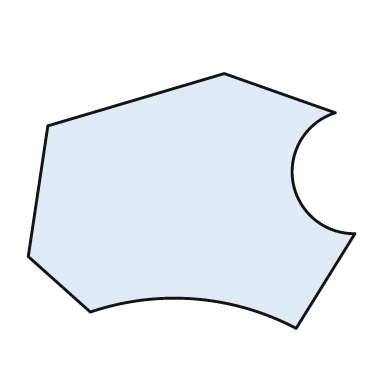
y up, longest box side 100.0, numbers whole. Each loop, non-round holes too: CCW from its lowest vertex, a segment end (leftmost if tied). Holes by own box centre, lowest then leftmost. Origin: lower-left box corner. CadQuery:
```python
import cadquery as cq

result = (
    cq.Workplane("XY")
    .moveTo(82.0, 0.0)
    .lineTo(100.0, 29.0)
    .threePointArc((81.0, 45.0), (94.0, 66.0))
    .lineTo(60.0, 78.0)
    .lineTo(6.0, 62.0)
    .lineTo(0.0, 22.0)
    .lineTo(19.0, 5.0)
    .threePointArc((51.0, 9.0), (82.0, 0.0))
    .close()
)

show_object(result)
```